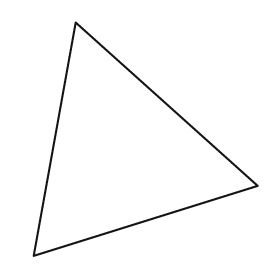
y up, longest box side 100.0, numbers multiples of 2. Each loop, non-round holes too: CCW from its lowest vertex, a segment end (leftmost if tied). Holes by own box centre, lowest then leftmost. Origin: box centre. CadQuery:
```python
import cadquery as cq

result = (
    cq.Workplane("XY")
    .moveTo(-48.0, -50.0)
    .lineTo(48.0, -20.0)
    .lineTo(-30.0, 50.0)
    .close()
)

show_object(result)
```